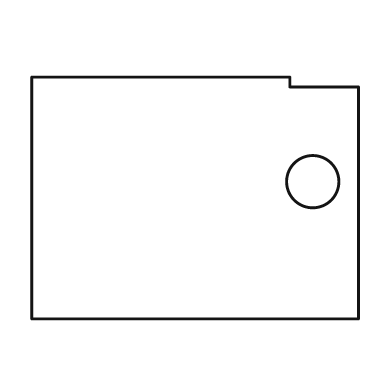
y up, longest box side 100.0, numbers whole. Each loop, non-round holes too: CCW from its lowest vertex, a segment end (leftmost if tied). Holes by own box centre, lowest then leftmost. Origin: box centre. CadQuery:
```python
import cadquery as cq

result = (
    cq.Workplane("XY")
    .moveTo(-50.0, -37.0)
    .lineTo(50.0, -37.0)
    .lineTo(50.0, 34.0)
    .lineTo(29.0, 34.0)
    .lineTo(29.0, 37.0)
    .lineTo(-50.0, 37.0)
    .close()
    .moveTo(36.0, 5.0)
    .circle(8.0)
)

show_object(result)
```